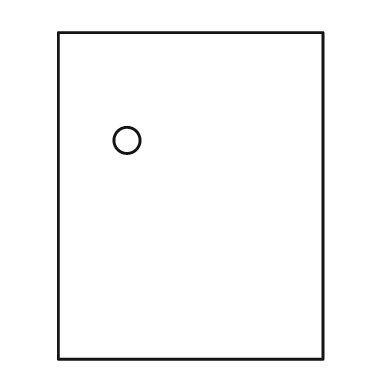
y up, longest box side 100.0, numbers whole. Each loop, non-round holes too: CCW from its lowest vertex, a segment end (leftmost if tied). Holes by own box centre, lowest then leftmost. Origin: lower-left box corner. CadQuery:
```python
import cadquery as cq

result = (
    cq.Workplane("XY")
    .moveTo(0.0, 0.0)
    .lineTo(81.0, 0.0)
    .lineTo(81.0, 100.0)
    .lineTo(0.0, 100.0)
    .close()
    .moveTo(21.0, 67.0)
    .circle(4.0)
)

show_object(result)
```